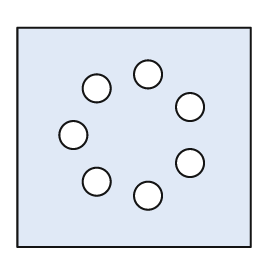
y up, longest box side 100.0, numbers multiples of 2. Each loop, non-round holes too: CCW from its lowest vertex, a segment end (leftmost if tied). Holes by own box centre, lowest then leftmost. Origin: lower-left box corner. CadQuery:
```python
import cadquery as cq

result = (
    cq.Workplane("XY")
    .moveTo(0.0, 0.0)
    .lineTo(100.0, 0.0)
    .lineTo(100.0, 94.0)
    .lineTo(0.0, 94.0)
    .close()
    .moveTo(56.0, 22.0)
    .circle(6.0)
    .moveTo(34.0, 28.0)
    .circle(6.0)
    .moveTo(74.0, 36.0)
    .circle(6.0)
    .moveTo(24.0, 48.0)
    .circle(6.0)
    .moveTo(74.0, 60.0)
    .circle(6.0)
    .moveTo(34.0, 68.0)
    .circle(6.0)
    .moveTo(56.0, 74.0)
    .circle(6.0)
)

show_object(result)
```